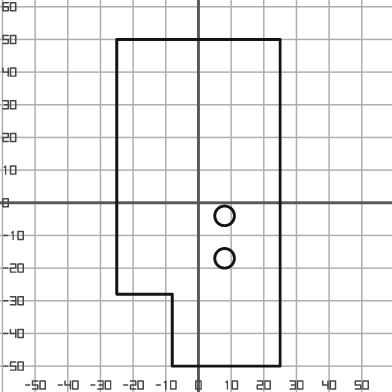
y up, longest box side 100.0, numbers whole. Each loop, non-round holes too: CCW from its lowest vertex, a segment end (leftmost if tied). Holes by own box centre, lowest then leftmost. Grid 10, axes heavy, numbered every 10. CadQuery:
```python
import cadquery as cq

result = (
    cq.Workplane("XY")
    .moveTo(-8.0, -50.0)
    .lineTo(25.0, -50.0)
    .lineTo(25.0, 50.0)
    .lineTo(-25.0, 50.0)
    .lineTo(-25.0, -28.0)
    .lineTo(-8.0, -28.0)
    .close()
    .moveTo(8.0, -17.0)
    .circle(3.0)
    .moveTo(8.0, -4.0)
    .circle(3.0)
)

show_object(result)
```